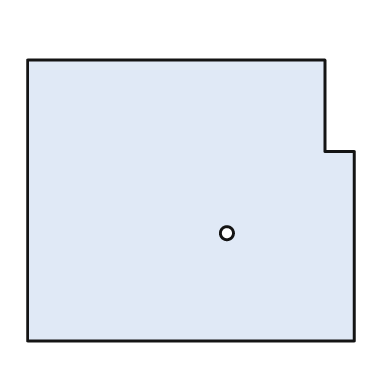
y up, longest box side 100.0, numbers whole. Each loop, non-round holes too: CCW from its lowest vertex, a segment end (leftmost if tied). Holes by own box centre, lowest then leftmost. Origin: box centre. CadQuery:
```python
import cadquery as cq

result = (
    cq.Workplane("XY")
    .moveTo(-50.0, -43.0)
    .lineTo(50.0, -43.0)
    .lineTo(50.0, 15.0)
    .lineTo(41.0, 15.0)
    .lineTo(41.0, 43.0)
    .lineTo(-50.0, 43.0)
    .close()
    .moveTo(11.0, -10.0)
    .circle(2.0)
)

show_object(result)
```